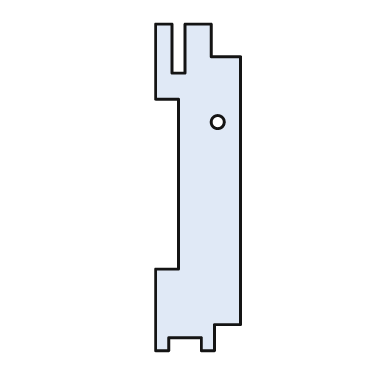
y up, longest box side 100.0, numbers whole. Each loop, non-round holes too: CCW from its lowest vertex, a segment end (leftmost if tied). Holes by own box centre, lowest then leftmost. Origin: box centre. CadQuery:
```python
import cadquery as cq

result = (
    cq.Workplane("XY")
    .moveTo(-13.0, -50.0)
    .lineTo(-9.0, -50.0)
    .lineTo(-9.0, -46.0)
    .lineTo(1.0, -46.0)
    .lineTo(1.0, -50.0)
    .lineTo(5.0, -50.0)
    .lineTo(5.0, -42.0)
    .lineTo(13.0, -42.0)
    .lineTo(13.0, 40.0)
    .lineTo(4.0, 40.0)
    .lineTo(4.0, 50.0)
    .lineTo(-4.0, 50.0)
    .lineTo(-4.0, 35.0)
    .lineTo(-8.0, 35.0)
    .lineTo(-8.0, 50.0)
    .lineTo(-13.0, 50.0)
    .lineTo(-13.0, 27.0)
    .lineTo(-6.0, 27.0)
    .lineTo(-6.0, -25.0)
    .lineTo(-13.0, -25.0)
    .close()
    .moveTo(6.0, 20.0)
    .circle(2.0)
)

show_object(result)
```